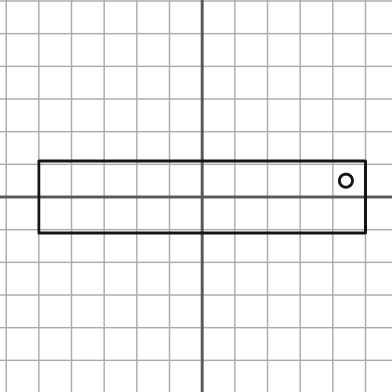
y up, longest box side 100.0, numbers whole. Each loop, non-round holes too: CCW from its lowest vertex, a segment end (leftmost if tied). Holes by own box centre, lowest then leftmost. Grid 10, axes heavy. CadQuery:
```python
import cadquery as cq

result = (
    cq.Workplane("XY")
    .moveTo(-50.0, -11.0)
    .lineTo(50.0, -11.0)
    .lineTo(50.0, 11.0)
    .lineTo(-50.0, 11.0)
    .close()
    .moveTo(44.0, 5.0)
    .circle(2.0)
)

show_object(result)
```